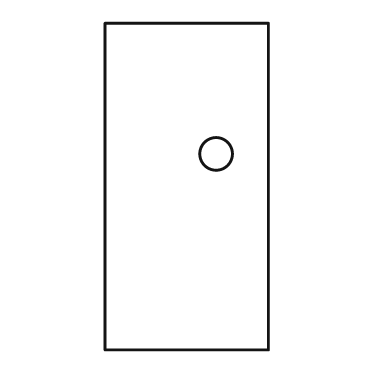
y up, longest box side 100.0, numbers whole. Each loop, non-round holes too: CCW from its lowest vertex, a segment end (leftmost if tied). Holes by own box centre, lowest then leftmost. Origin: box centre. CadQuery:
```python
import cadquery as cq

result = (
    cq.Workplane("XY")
    .moveTo(-25.0, -50.0)
    .lineTo(25.0, -50.0)
    .lineTo(25.0, 50.0)
    .lineTo(-25.0, 50.0)
    .close()
    .moveTo(9.0, 10.0)
    .circle(5.0)
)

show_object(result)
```